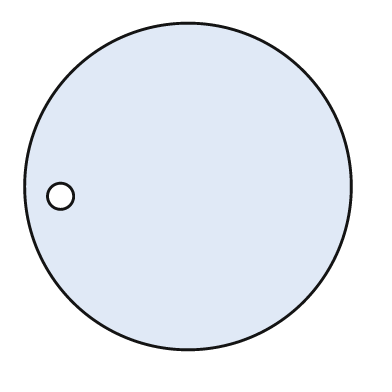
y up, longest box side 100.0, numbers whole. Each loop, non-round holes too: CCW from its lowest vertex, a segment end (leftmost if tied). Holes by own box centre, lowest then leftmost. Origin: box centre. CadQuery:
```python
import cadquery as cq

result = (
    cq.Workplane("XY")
    .moveTo(0.0, 0.0)
    .circle(50.0)
    .moveTo(-39.0, -3.0)
    .circle(4.0)
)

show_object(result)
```